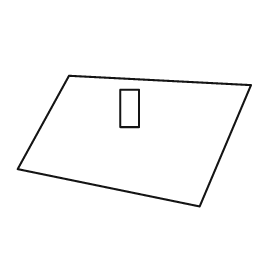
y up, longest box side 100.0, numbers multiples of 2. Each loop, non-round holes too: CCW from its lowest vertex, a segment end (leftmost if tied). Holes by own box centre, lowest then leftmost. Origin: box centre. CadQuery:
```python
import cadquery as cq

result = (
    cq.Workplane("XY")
    .moveTo(28.0, -28.0)
    .lineTo(50.0, 24.0)
    .lineTo(-28.0, 28.0)
    .lineTo(-50.0, -12.0)
    .close()
    .moveTo(-6.0, 6.0)
    .lineTo(2.0, 6.0)
    .lineTo(2.0, 22.0)
    .lineTo(-6.0, 22.0)
    .close()
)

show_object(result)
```